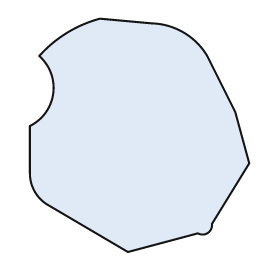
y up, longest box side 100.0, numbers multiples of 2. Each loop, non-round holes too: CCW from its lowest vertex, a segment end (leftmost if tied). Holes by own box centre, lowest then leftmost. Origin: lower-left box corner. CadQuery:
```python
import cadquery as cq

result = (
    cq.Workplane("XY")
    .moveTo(42.0, 0.0)
    .lineTo(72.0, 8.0)
    .threePointArc((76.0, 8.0), (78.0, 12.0))
    .lineTo(94.0, 38.0)
    .lineTo(88.0, 60.0)
    .lineTo(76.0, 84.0)
    .threePointArc((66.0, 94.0), (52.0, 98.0))
    .lineTo(30.0, 100.0)
    .threePointArc((16.0, 94.0), (4.0, 84.0))
    .threePointArc((10.0, 68.0), (0.0, 54.0))
    .lineTo(0.0, 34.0)
    .threePointArc((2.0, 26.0), (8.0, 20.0))
    .close()
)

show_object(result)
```